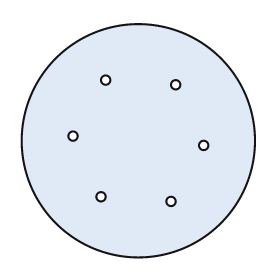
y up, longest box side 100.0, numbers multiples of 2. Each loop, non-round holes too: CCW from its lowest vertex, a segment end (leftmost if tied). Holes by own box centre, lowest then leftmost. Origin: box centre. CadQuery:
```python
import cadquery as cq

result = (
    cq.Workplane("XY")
    .moveTo(0.0, 0.0)
    .circle(50.0)
    .moveTo(14.0, -26.0)
    .circle(2.0)
    .moveTo(-16.0, -24.0)
    .circle(2.0)
    .moveTo(28.0, -2.0)
    .circle(2.0)
    .moveTo(-28.0, 2.0)
    .circle(2.0)
    .moveTo(16.0, 24.0)
    .circle(2.0)
    .moveTo(-14.0, 26.0)
    .circle(2.0)
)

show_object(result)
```